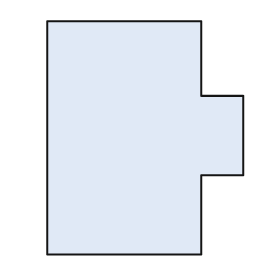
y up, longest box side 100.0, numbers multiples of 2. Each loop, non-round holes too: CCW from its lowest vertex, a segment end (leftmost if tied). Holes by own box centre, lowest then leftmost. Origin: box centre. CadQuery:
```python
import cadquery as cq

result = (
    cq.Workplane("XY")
    .moveTo(-42.0, -50.0)
    .lineTo(24.0, -50.0)
    .lineTo(24.0, -16.0)
    .lineTo(42.0, -16.0)
    .lineTo(42.0, 18.0)
    .lineTo(24.0, 18.0)
    .lineTo(24.0, 50.0)
    .lineTo(-42.0, 50.0)
    .close()
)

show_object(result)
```